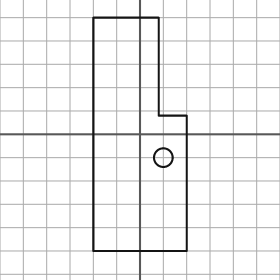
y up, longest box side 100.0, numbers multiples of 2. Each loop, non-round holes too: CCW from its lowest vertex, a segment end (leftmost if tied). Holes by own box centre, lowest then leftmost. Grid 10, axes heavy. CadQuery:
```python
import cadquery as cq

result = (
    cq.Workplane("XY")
    .moveTo(-20.0, -50.0)
    .lineTo(20.0, -50.0)
    .lineTo(20.0, 8.0)
    .lineTo(8.0, 8.0)
    .lineTo(8.0, 50.0)
    .lineTo(-20.0, 50.0)
    .close()
    .moveTo(10.0, -10.0)
    .circle(4.0)
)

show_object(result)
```